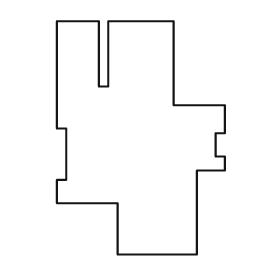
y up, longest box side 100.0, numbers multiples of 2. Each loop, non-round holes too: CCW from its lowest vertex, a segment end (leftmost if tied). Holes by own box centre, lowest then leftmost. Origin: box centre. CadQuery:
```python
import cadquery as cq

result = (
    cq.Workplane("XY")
    .moveTo(-10.0, -50.0)
    .lineTo(24.0, -50.0)
    .lineTo(24.0, -14.0)
    .lineTo(36.0, -14.0)
    .lineTo(36.0, -8.0)
    .lineTo(32.0, -8.0)
    .lineTo(32.0, 2.0)
    .lineTo(36.0, 2.0)
    .lineTo(36.0, 14.0)
    .lineTo(14.0, 14.0)
    .lineTo(14.0, 50.0)
    .lineTo(-14.0, 50.0)
    .lineTo(-14.0, 22.0)
    .lineTo(-18.0, 22.0)
    .lineTo(-18.0, 50.0)
    .lineTo(-36.0, 50.0)
    .lineTo(-36.0, 4.0)
    .lineTo(-32.0, 4.0)
    .lineTo(-32.0, -18.0)
    .lineTo(-36.0, -18.0)
    .lineTo(-36.0, -28.0)
    .lineTo(-10.0, -28.0)
    .close()
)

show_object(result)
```